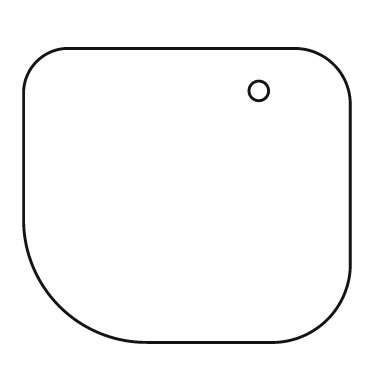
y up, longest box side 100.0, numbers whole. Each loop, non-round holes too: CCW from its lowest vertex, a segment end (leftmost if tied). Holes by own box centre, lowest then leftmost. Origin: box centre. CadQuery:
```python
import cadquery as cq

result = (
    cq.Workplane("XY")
    .moveTo(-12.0, -45.0)
    .lineTo(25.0, -45.0)
    .threePointArc((43.0, -38.0), (50.0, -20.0))
    .lineTo(50.0, 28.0)
    .threePointArc((45.0, 40.0), (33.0, 45.0))
    .lineTo(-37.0, 45.0)
    .threePointArc((-46.0, 41.0), (-50.0, 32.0))
    .lineTo(-50.0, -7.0)
    .threePointArc((-39.0, -34.0), (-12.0, -45.0))
    .close()
    .moveTo(22.0, 32.0)
    .circle(3.0)
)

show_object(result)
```